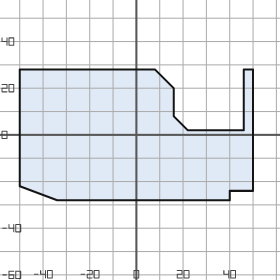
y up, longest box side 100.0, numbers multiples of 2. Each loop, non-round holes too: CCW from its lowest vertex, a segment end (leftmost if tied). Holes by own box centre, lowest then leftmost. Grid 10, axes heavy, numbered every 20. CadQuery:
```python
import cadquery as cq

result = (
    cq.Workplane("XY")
    .moveTo(-34.0, -28.0)
    .lineTo(40.0, -28.0)
    .lineTo(40.0, -24.0)
    .lineTo(50.0, -24.0)
    .lineTo(50.0, 28.0)
    .lineTo(46.0, 28.0)
    .lineTo(46.0, 2.0)
    .lineTo(22.0, 2.0)
    .lineTo(16.0, 8.0)
    .lineTo(16.0, 20.0)
    .lineTo(8.0, 28.0)
    .lineTo(-50.0, 28.0)
    .lineTo(-50.0, -22.0)
    .close()
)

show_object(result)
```